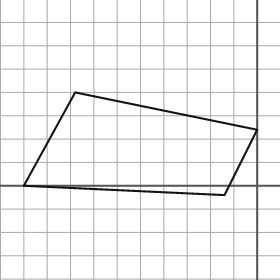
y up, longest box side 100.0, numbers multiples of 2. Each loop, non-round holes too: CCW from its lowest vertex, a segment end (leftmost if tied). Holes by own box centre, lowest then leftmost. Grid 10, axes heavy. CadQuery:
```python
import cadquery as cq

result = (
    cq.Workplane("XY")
    .moveTo(-14.0, -4.0)
    .lineTo(0.0, 24.0)
    .lineTo(-78.0, 40.0)
    .lineTo(-100.0, 0.0)
    .close()
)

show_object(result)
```